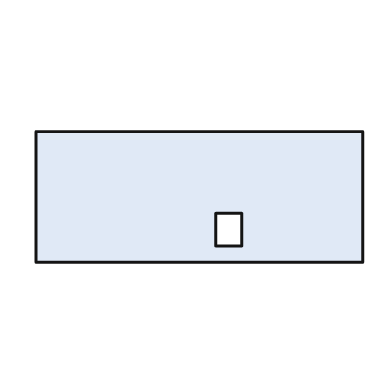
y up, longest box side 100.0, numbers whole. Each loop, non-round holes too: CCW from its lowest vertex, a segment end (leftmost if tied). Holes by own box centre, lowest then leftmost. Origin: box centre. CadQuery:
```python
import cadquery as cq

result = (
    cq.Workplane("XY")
    .moveTo(-50.0, -20.0)
    .lineTo(50.0, -20.0)
    .lineTo(50.0, 20.0)
    .lineTo(-50.0, 20.0)
    .close()
    .moveTo(5.0, -15.0)
    .lineTo(13.0, -15.0)
    .lineTo(13.0, -5.0)
    .lineTo(5.0, -5.0)
    .close()
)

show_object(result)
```